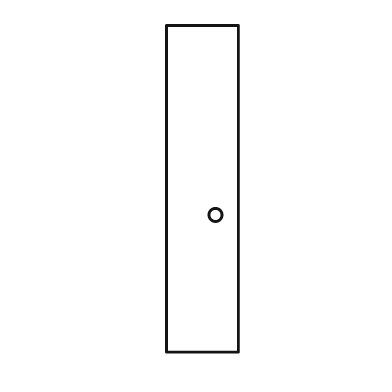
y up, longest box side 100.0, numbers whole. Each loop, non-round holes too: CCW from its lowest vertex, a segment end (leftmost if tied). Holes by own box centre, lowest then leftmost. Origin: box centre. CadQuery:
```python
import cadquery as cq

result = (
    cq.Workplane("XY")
    .moveTo(-11.0, -50.0)
    .lineTo(11.0, -50.0)
    .lineTo(11.0, 50.0)
    .lineTo(-11.0, 50.0)
    .close()
    .moveTo(4.0, -8.0)
    .circle(2.0)
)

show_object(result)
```